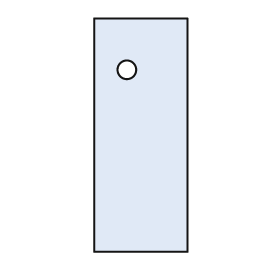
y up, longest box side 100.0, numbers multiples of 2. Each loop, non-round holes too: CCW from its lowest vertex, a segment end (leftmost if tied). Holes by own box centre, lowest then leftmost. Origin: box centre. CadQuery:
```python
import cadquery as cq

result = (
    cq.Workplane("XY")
    .moveTo(-20.0, -50.0)
    .lineTo(20.0, -50.0)
    .lineTo(20.0, 50.0)
    .lineTo(-20.0, 50.0)
    .close()
    .moveTo(-6.0, 28.0)
    .circle(4.0)
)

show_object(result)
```